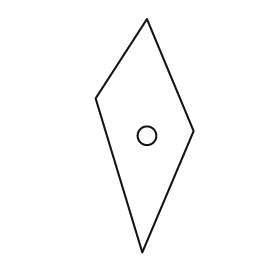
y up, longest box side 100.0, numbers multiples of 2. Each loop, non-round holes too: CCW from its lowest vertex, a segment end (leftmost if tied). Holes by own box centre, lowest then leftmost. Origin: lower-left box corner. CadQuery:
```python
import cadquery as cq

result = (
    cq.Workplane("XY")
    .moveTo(20.0, 0.0)
    .lineTo(42.0, 52.0)
    .lineTo(22.0, 100.0)
    .lineTo(0.0, 66.0)
    .close()
    .moveTo(22.0, 50.0)
    .circle(4.0)
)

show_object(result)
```